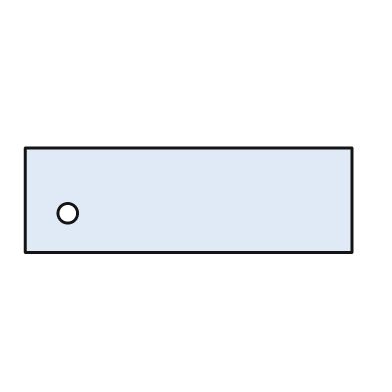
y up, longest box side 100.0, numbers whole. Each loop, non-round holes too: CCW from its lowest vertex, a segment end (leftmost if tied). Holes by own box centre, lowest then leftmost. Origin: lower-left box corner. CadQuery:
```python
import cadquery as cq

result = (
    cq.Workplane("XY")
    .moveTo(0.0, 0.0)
    .lineTo(100.0, 0.0)
    .lineTo(100.0, 32.0)
    .lineTo(0.0, 32.0)
    .close()
    .moveTo(13.0, 12.0)
    .circle(3.0)
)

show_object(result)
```